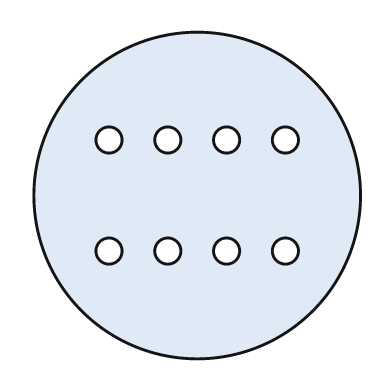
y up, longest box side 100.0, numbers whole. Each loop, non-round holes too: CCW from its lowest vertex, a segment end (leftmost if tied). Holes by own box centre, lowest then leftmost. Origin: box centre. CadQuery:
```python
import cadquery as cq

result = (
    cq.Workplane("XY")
    .moveTo(0.0, 0.0)
    .circle(50.0)
    .moveTo(-27.0, -17.0)
    .circle(4.0)
    .moveTo(-9.0, -17.0)
    .circle(4.0)
    .moveTo(9.0, -17.0)
    .circle(4.0)
    .moveTo(27.0, -17.0)
    .circle(4.0)
    .moveTo(-27.0, 17.0)
    .circle(4.0)
    .moveTo(-9.0, 17.0)
    .circle(4.0)
    .moveTo(9.0, 17.0)
    .circle(4.0)
    .moveTo(27.0, 17.0)
    .circle(4.0)
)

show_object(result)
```